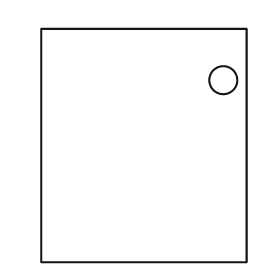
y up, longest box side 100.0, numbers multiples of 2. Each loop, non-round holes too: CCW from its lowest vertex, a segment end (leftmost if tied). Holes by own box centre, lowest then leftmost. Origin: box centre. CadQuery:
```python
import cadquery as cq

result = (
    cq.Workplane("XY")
    .moveTo(-44.0, -50.0)
    .lineTo(44.0, -50.0)
    .lineTo(44.0, 50.0)
    .lineTo(-44.0, 50.0)
    .close()
    .moveTo(34.0, 28.0)
    .circle(6.0)
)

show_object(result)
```